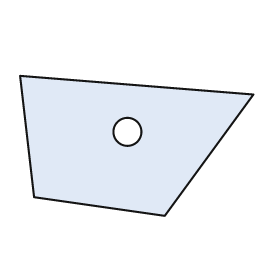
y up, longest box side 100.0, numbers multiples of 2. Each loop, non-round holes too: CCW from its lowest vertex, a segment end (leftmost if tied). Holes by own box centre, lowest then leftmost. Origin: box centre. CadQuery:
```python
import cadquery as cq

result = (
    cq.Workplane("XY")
    .moveTo(12.0, -30.0)
    .lineTo(50.0, 22.0)
    .lineTo(-50.0, 30.0)
    .lineTo(-44.0, -22.0)
    .close()
    .moveTo(-4.0, 6.0)
    .circle(6.0)
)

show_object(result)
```